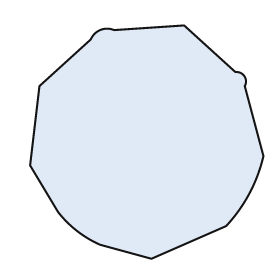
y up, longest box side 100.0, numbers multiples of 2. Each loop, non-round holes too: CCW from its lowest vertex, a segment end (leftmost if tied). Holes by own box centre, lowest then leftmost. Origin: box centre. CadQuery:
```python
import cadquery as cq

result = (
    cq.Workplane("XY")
    .moveTo(2.0, -50.0)
    .lineTo(34.0, -36.0)
    .threePointArc((44.0, -22.0), (50.0, -6.0))
    .lineTo(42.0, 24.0)
    .threePointArc((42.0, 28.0), (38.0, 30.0))
    .lineTo(16.0, 50.0)
    .lineTo(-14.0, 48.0)
    .threePointArc((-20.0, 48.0), (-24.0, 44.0))
    .lineTo(-46.0, 24.0)
    .lineTo(-50.0, -10.0)
    .lineTo(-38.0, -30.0)
    .threePointArc((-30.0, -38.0), (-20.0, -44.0))
    .close()
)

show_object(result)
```